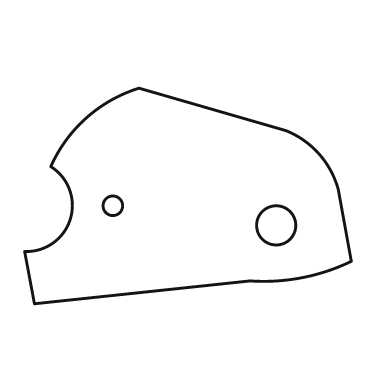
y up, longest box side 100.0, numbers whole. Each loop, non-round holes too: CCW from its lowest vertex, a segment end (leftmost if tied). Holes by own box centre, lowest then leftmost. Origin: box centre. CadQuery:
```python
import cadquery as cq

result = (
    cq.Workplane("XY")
    .moveTo(-47.0, -33.0)
    .lineTo(19.0, -26.0)
    .threePointArc((35.0, -25.0), (50.0, -20.0))
    .lineTo(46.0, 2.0)
    .threePointArc((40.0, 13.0), (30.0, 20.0))
    .lineTo(-15.0, 33.0)
    .threePointArc((-31.0, 24.0), (-42.0, 9.0))
    .threePointArc((-36.0, -7.0), (-50.0, -17.0))
    .close()
    .moveTo(27.0, -9.0)
    .circle(6.0)
    .moveTo(-23.0, -3.0)
    .circle(3.0)
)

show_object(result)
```